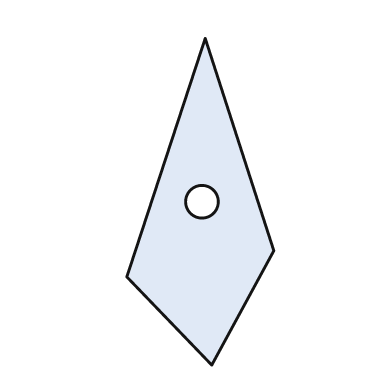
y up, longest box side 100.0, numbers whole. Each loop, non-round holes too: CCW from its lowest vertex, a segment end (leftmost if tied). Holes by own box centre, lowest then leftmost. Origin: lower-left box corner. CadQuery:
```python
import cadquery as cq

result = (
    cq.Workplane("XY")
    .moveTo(26.0, 0.0)
    .lineTo(45.0, 35.0)
    .lineTo(24.0, 100.0)
    .lineTo(0.0, 27.0)
    .close()
    .moveTo(23.0, 50.0)
    .circle(5.0)
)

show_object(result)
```